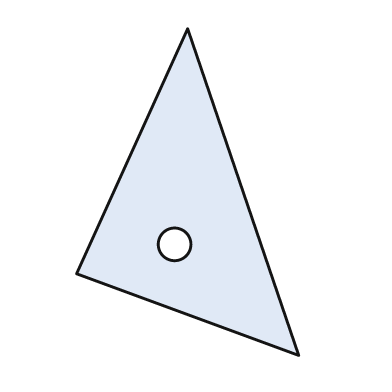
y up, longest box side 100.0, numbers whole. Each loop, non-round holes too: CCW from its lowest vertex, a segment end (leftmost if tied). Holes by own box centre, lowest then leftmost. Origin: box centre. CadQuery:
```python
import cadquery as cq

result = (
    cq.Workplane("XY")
    .moveTo(34.0, -50.0)
    .lineTo(0.0, 50.0)
    .lineTo(-34.0, -25.0)
    .close()
    .moveTo(-4.0, -16.0)
    .circle(5.0)
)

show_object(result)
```